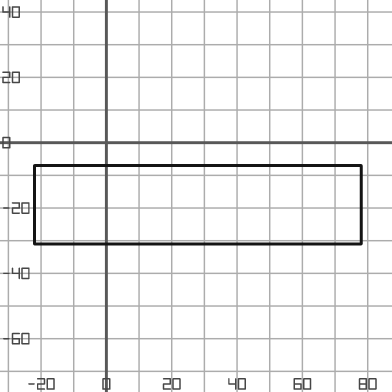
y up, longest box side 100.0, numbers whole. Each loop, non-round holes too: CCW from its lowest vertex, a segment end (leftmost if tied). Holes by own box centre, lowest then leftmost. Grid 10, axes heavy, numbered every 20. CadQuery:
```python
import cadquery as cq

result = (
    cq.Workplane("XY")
    .moveTo(-22.0, -31.0)
    .lineTo(78.0, -31.0)
    .lineTo(78.0, -7.0)
    .lineTo(-22.0, -7.0)
    .close()
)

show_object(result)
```